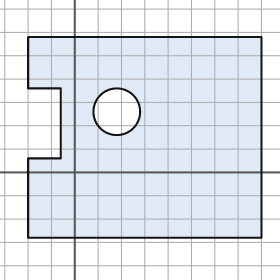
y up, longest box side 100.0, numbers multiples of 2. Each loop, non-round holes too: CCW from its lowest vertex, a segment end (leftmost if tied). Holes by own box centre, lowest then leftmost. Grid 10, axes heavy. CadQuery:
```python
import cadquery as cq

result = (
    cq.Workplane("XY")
    .moveTo(-20.0, -28.0)
    .lineTo(80.0, -28.0)
    .lineTo(80.0, 58.0)
    .lineTo(-20.0, 58.0)
    .lineTo(-20.0, 36.0)
    .lineTo(-6.0, 36.0)
    .lineTo(-6.0, 6.0)
    .lineTo(-20.0, 6.0)
    .close()
    .moveTo(18.0, 26.0)
    .circle(10.0)
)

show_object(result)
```